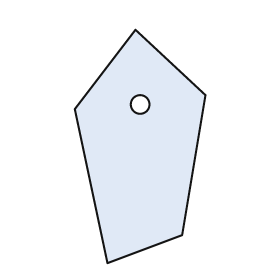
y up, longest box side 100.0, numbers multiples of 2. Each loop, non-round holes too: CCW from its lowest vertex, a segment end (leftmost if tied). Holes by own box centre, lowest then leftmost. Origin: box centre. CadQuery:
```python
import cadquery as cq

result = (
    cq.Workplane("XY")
    .moveTo(-14.0, -50.0)
    .lineTo(18.0, -38.0)
    .lineTo(28.0, 22.0)
    .lineTo(-2.0, 50.0)
    .lineTo(-28.0, 16.0)
    .close()
    .moveTo(0.0, 18.0)
    .circle(4.0)
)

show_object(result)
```